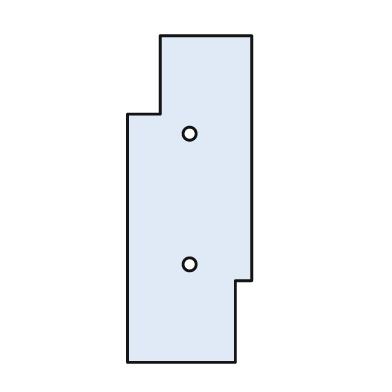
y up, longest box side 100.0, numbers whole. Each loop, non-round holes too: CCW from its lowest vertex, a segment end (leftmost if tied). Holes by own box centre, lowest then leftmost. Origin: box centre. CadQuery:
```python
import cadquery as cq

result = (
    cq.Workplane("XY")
    .moveTo(-19.0, -50.0)
    .lineTo(14.0, -50.0)
    .lineTo(14.0, -25.0)
    .lineTo(19.0, -25.0)
    .lineTo(19.0, 50.0)
    .lineTo(-9.0, 50.0)
    .lineTo(-9.0, 26.0)
    .lineTo(-19.0, 26.0)
    .close()
    .moveTo(0.0, -20.0)
    .circle(2.0)
    .moveTo(0.0, 20.0)
    .circle(2.0)
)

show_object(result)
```